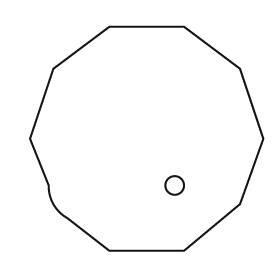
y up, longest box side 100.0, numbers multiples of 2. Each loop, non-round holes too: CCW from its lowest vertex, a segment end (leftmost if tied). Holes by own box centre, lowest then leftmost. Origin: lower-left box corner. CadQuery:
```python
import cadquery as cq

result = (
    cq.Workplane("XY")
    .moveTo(34.0, 0.0)
    .lineTo(66.0, 0.0)
    .lineTo(90.0, 20.0)
    .lineTo(100.0, 48.0)
    .lineTo(90.0, 78.0)
    .lineTo(66.0, 96.0)
    .lineTo(34.0, 96.0)
    .lineTo(10.0, 78.0)
    .lineTo(0.0, 48.0)
    .lineTo(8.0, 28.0)
    .threePointArc((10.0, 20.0), (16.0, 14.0))
    .close()
    .moveTo(62.0, 28.0)
    .circle(4.0)
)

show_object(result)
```